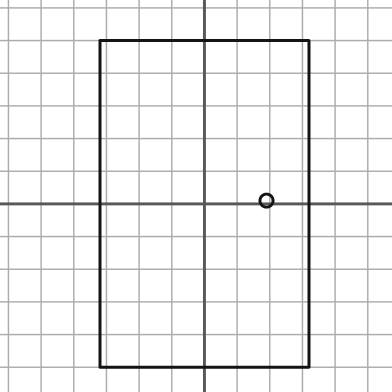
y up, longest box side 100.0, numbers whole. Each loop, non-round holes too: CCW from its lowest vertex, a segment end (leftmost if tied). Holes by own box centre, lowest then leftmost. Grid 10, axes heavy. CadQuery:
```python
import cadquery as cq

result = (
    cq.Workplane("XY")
    .moveTo(-32.0, -50.0)
    .lineTo(32.0, -50.0)
    .lineTo(32.0, 50.0)
    .lineTo(-32.0, 50.0)
    .close()
    .moveTo(19.0, 1.0)
    .circle(2.0)
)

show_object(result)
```